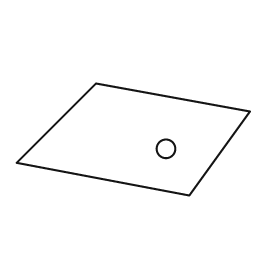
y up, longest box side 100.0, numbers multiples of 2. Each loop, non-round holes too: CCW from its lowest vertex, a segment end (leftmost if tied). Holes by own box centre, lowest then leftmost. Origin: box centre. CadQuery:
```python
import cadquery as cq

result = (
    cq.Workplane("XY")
    .moveTo(24.0, -24.0)
    .lineTo(50.0, 12.0)
    .lineTo(-16.0, 24.0)
    .lineTo(-50.0, -10.0)
    .close()
    .moveTo(14.0, -4.0)
    .circle(4.0)
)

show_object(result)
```